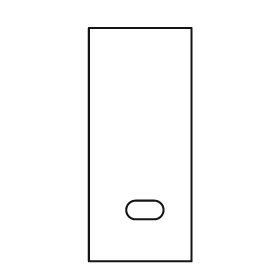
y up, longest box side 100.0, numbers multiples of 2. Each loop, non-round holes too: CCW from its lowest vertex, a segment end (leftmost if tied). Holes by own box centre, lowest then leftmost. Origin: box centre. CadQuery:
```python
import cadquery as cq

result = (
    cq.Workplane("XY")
    .moveTo(-22.0, -50.0)
    .lineTo(22.0, -50.0)
    .lineTo(22.0, 50.0)
    .lineTo(-22.0, 50.0)
    .close()
    .moveTo(-2.0, -32.0)
    .lineTo(6.0, -32.0)
    .threePointArc((10.0, -28.0), (6.0, -24.0))
    .lineTo(-2.0, -24.0)
    .threePointArc((-6.0, -28.0), (-2.0, -32.0))
    .close()
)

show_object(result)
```